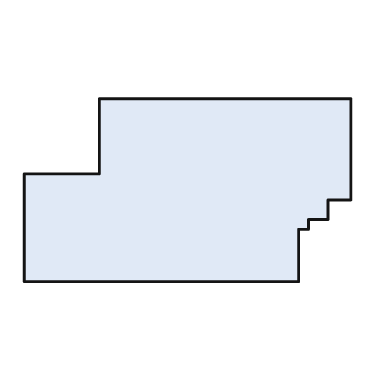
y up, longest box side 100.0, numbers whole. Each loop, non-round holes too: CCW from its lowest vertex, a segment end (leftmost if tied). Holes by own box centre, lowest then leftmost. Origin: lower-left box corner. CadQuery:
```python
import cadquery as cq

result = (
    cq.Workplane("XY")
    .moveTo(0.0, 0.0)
    .lineTo(84.0, 0.0)
    .lineTo(84.0, 16.0)
    .lineTo(87.0, 16.0)
    .lineTo(87.0, 19.0)
    .lineTo(93.0, 19.0)
    .lineTo(93.0, 25.0)
    .lineTo(100.0, 25.0)
    .lineTo(100.0, 56.0)
    .lineTo(23.0, 56.0)
    .lineTo(23.0, 33.0)
    .lineTo(0.0, 33.0)
    .close()
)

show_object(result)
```